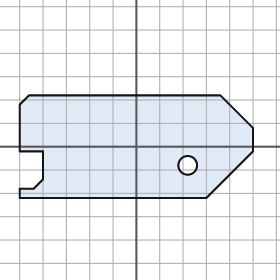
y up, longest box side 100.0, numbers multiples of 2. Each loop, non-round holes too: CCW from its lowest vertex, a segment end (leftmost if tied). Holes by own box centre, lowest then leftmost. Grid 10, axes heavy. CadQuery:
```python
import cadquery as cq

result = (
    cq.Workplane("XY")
    .moveTo(-50.0, -22.0)
    .lineTo(30.0, -22.0)
    .lineTo(50.0, -2.0)
    .lineTo(50.0, 8.0)
    .lineTo(36.0, 22.0)
    .lineTo(-46.0, 22.0)
    .lineTo(-50.0, 18.0)
    .lineTo(-50.0, -2.0)
    .lineTo(-40.0, -2.0)
    .lineTo(-40.0, -14.0)
    .lineTo(-44.0, -18.0)
    .lineTo(-50.0, -18.0)
    .close()
    .moveTo(22.0, -8.0)
    .circle(4.0)
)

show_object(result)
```